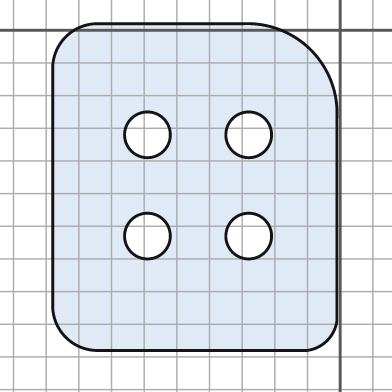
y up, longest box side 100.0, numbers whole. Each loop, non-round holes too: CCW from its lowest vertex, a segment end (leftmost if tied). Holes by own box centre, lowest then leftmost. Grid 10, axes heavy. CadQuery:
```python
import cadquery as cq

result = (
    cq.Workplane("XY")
    .moveTo(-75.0, -98.0)
    .lineTo(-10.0, -98.0)
    .threePointArc((-4.0, -95.0), (-1.0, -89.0))
    .lineTo(-1.0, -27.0)
    .threePointArc((-9.0, -6.0), (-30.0, 2.0))
    .lineTo(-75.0, 2.0)
    .threePointArc((-84.0, -2.0), (-88.0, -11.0))
    .lineTo(-88.0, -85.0)
    .threePointArc((-84.0, -94.0), (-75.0, -98.0))
    .close()
    .moveTo(-59.0, -63.0)
    .circle(7.0)
    .moveTo(-28.0, -63.0)
    .circle(7.0)
    .moveTo(-59.0, -32.0)
    .circle(7.0)
    .moveTo(-28.0, -32.0)
    .circle(7.0)
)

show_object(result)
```